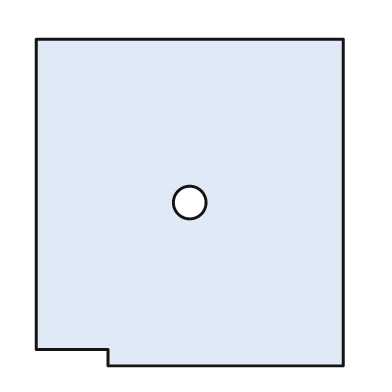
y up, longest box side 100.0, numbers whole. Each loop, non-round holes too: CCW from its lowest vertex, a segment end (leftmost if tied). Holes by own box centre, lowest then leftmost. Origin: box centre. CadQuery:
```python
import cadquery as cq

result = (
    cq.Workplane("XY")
    .moveTo(-25.0, -50.0)
    .lineTo(47.0, -50.0)
    .lineTo(47.0, 50.0)
    .lineTo(-47.0, 50.0)
    .lineTo(-47.0, -45.0)
    .lineTo(-25.0, -45.0)
    .close()
    .moveTo(0.0, 0.0)
    .circle(5.0)
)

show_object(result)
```